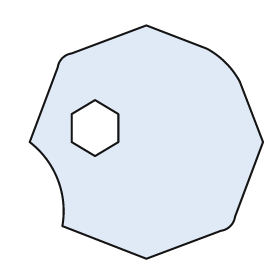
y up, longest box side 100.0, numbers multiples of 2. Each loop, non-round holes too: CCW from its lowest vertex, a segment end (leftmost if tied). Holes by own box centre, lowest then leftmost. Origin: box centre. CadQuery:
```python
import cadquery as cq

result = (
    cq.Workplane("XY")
    .moveTo(0.0, -50.0)
    .lineTo(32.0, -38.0)
    .threePointArc((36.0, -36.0), (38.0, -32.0))
    .lineTo(50.0, 0.0)
    .lineTo(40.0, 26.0)
    .threePointArc((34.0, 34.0), (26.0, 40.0))
    .lineTo(0.0, 50.0)
    .lineTo(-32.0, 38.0)
    .threePointArc((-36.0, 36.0), (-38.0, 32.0))
    .lineTo(-50.0, 0.0)
    .threePointArc((-38.0, -16.0), (-36.0, -36.0))
    .close()
    .moveTo(-22.0, -6.0)
    .lineTo(-12.0, 0.0)
    .lineTo(-12.0, 12.0)
    .lineTo(-22.0, 18.0)
    .lineTo(-32.0, 12.0)
    .lineTo(-32.0, 0.0)
    .close()
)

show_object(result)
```